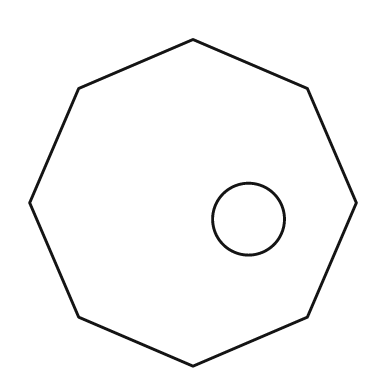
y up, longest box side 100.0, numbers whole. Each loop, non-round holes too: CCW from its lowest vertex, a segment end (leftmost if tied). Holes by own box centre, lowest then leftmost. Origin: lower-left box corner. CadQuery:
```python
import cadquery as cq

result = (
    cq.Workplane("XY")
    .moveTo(50.0, 0.0)
    .lineTo(85.0, 15.0)
    .lineTo(100.0, 50.0)
    .lineTo(85.0, 85.0)
    .lineTo(50.0, 100.0)
    .lineTo(15.0, 85.0)
    .lineTo(0.0, 50.0)
    .lineTo(15.0, 15.0)
    .close()
    .moveTo(67.0, 45.0)
    .circle(11.0)
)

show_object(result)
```